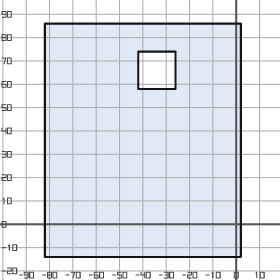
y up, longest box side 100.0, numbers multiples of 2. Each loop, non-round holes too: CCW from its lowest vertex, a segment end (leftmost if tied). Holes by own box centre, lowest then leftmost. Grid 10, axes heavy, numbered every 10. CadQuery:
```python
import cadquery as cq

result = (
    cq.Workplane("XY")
    .moveTo(-82.0, -14.0)
    .lineTo(2.0, -14.0)
    .lineTo(2.0, 86.0)
    .lineTo(-82.0, 86.0)
    .close()
    .moveTo(-42.0, 58.0)
    .lineTo(-26.0, 58.0)
    .lineTo(-26.0, 74.0)
    .lineTo(-42.0, 74.0)
    .close()
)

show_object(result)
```